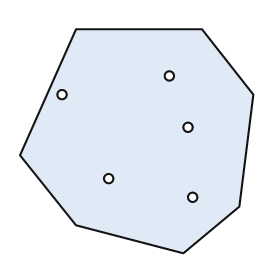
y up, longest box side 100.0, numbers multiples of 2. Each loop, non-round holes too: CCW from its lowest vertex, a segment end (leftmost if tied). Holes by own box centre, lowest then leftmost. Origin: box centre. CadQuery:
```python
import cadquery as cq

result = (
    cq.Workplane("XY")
    .moveTo(20.0, -48.0)
    .lineTo(44.0, -28.0)
    .lineTo(50.0, 20.0)
    .lineTo(28.0, 48.0)
    .lineTo(-26.0, 48.0)
    .lineTo(-50.0, -6.0)
    .lineTo(-26.0, -36.0)
    .close()
    .moveTo(24.0, -24.0)
    .circle(2.0)
    .moveTo(-12.0, -16.0)
    .circle(2.0)
    .moveTo(22.0, 6.0)
    .circle(2.0)
    .moveTo(-32.0, 20.0)
    .circle(2.0)
    .moveTo(14.0, 28.0)
    .circle(2.0)
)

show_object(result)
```